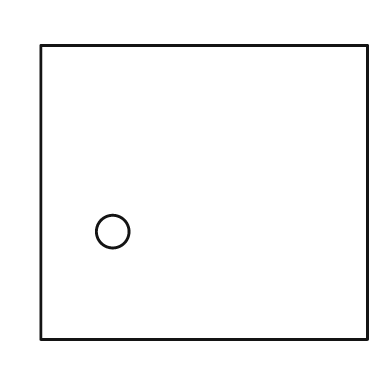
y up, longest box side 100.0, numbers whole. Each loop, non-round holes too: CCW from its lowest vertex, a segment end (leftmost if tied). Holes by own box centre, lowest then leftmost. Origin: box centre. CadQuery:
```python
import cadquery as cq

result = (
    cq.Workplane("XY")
    .moveTo(-50.0, -45.0)
    .lineTo(50.0, -45.0)
    .lineTo(50.0, 45.0)
    .lineTo(-50.0, 45.0)
    .close()
    .moveTo(-28.0, -12.0)
    .circle(5.0)
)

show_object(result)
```